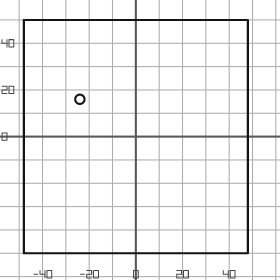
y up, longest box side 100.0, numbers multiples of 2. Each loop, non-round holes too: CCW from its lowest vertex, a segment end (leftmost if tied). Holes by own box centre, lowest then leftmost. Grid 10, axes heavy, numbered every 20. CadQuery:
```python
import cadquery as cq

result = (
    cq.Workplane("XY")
    .moveTo(-48.0, -50.0)
    .lineTo(48.0, -50.0)
    .lineTo(48.0, 50.0)
    .lineTo(-48.0, 50.0)
    .close()
    .moveTo(-24.0, 16.0)
    .circle(2.0)
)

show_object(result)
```